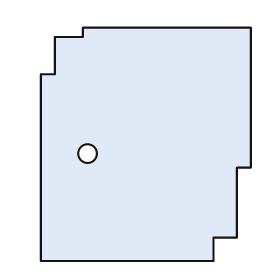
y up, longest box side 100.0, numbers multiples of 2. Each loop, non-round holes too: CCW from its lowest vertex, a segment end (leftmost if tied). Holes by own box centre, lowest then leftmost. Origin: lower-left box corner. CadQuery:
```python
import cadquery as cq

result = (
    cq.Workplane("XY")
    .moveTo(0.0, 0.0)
    .lineTo(74.0, 0.0)
    .lineTo(74.0, 10.0)
    .lineTo(84.0, 10.0)
    .lineTo(84.0, 40.0)
    .lineTo(90.0, 40.0)
    .lineTo(90.0, 100.0)
    .lineTo(18.0, 100.0)
    .lineTo(18.0, 96.0)
    .lineTo(6.0, 96.0)
    .lineTo(6.0, 80.0)
    .lineTo(0.0, 80.0)
    .close()
    .moveTo(20.0, 46.0)
    .circle(4.0)
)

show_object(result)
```